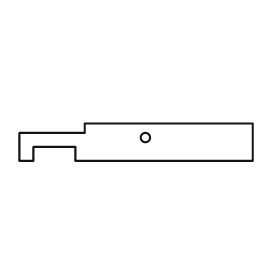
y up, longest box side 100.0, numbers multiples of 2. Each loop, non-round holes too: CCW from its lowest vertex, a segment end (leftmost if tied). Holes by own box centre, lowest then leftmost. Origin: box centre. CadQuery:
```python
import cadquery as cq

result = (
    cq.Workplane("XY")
    .moveTo(-50.0, -8.0)
    .lineTo(-44.0, -8.0)
    .lineTo(-44.0, -2.0)
    .lineTo(-26.0, -2.0)
    .lineTo(-26.0, -8.0)
    .lineTo(50.0, -8.0)
    .lineTo(50.0, 8.0)
    .lineTo(-22.0, 8.0)
    .lineTo(-22.0, 4.0)
    .lineTo(-50.0, 4.0)
    .close()
    .moveTo(4.0, 2.0)
    .circle(2.0)
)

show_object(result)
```